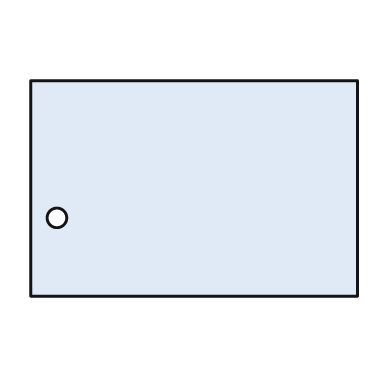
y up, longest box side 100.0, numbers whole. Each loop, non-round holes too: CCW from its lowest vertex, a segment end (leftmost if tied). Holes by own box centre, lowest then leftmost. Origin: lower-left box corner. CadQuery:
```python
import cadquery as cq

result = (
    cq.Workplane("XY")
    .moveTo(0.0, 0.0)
    .lineTo(100.0, 0.0)
    .lineTo(100.0, 66.0)
    .lineTo(0.0, 66.0)
    .close()
    .moveTo(8.0, 24.0)
    .circle(3.0)
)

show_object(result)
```